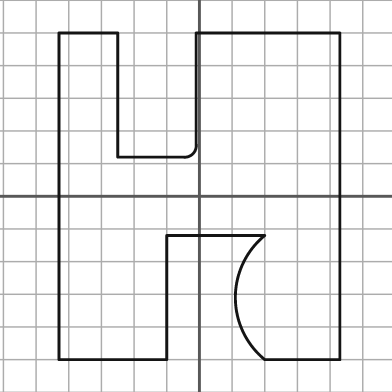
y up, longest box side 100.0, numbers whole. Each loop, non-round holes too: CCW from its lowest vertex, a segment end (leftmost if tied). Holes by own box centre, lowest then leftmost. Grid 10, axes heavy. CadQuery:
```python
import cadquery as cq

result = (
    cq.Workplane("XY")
    .moveTo(-43.0, -50.0)
    .lineTo(-10.0, -50.0)
    .lineTo(-10.0, -12.0)
    .lineTo(20.0, -12.0)
    .threePointArc((11.0, -31.0), (20.0, -50.0))
    .lineTo(43.0, -50.0)
    .lineTo(43.0, 50.0)
    .lineTo(-1.0, 50.0)
    .lineTo(-1.0, 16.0)
    .threePointArc((-2.0, 13.0), (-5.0, 12.0))
    .lineTo(-25.0, 12.0)
    .lineTo(-25.0, 50.0)
    .lineTo(-43.0, 50.0)
    .close()
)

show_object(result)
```